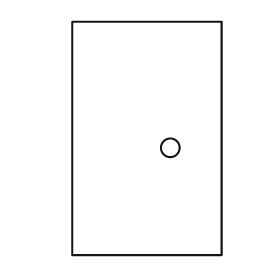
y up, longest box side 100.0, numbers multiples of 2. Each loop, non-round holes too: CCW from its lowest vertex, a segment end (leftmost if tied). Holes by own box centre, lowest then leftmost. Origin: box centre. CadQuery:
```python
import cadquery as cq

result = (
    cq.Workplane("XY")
    .moveTo(-32.0, -50.0)
    .lineTo(32.0, -50.0)
    .lineTo(32.0, 50.0)
    .lineTo(-32.0, 50.0)
    .close()
    .moveTo(10.0, -4.0)
    .circle(4.0)
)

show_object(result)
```